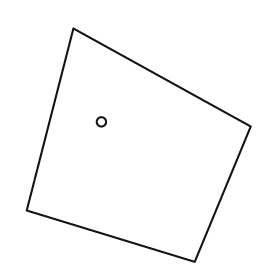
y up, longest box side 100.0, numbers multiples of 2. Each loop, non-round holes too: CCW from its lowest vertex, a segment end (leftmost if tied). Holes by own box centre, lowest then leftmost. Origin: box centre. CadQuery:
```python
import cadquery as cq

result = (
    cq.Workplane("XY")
    .moveTo(24.0, -50.0)
    .lineTo(48.0, 8.0)
    .lineTo(-28.0, 50.0)
    .lineTo(-48.0, -28.0)
    .close()
    .moveTo(-16.0, 10.0)
    .circle(2.0)
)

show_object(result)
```